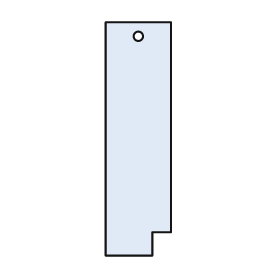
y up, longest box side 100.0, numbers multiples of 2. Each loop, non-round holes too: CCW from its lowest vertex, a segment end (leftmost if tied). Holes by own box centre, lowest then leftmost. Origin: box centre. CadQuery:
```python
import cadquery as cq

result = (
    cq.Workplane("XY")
    .moveTo(-14.0, -50.0)
    .lineTo(6.0, -50.0)
    .lineTo(6.0, -40.0)
    .lineTo(14.0, -40.0)
    .lineTo(14.0, 50.0)
    .lineTo(-14.0, 50.0)
    .close()
    .moveTo(0.0, 44.0)
    .circle(2.0)
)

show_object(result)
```